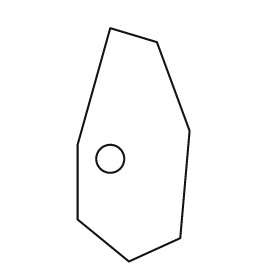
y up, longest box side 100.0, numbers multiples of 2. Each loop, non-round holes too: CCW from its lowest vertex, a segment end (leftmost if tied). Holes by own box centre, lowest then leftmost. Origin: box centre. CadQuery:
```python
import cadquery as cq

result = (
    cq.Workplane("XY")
    .moveTo(-2.0, -50.0)
    .lineTo(20.0, -40.0)
    .lineTo(24.0, 6.0)
    .lineTo(10.0, 44.0)
    .lineTo(-10.0, 50.0)
    .lineTo(-24.0, 0.0)
    .lineTo(-24.0, -32.0)
    .close()
    .moveTo(-10.0, -6.0)
    .circle(6.0)
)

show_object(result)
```